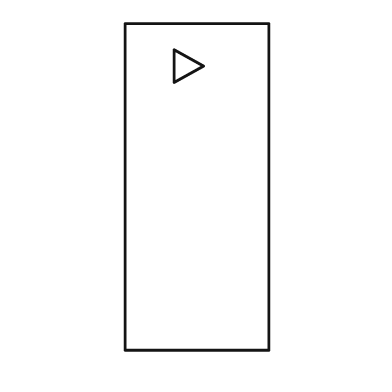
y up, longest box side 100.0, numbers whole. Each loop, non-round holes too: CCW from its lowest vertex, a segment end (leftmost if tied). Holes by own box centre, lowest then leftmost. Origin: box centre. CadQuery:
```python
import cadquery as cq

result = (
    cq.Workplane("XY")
    .moveTo(-22.0, -50.0)
    .lineTo(22.0, -50.0)
    .lineTo(22.0, 50.0)
    .lineTo(-22.0, 50.0)
    .close()
    .moveTo(-7.0, 32.0)
    .lineTo(2.0, 37.0)
    .lineTo(-7.0, 42.0)
    .close()
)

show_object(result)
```